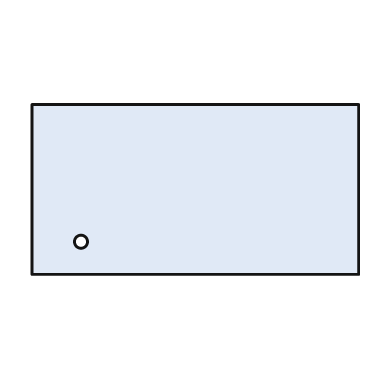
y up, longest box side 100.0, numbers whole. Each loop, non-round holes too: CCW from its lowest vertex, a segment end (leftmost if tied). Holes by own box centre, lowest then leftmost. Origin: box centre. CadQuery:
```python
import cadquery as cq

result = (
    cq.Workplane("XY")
    .moveTo(-50.0, -26.0)
    .lineTo(50.0, -26.0)
    .lineTo(50.0, 26.0)
    .lineTo(-50.0, 26.0)
    .close()
    .moveTo(-35.0, -16.0)
    .circle(2.0)
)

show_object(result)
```